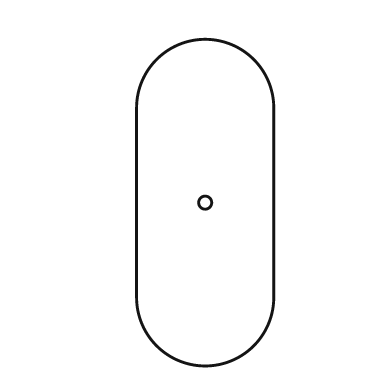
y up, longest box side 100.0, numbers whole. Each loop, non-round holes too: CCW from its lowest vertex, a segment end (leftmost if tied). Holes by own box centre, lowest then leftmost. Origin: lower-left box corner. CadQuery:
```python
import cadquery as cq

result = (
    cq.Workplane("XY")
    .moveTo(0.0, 21.0)
    .threePointArc((21.0, 0.0), (42.0, 21.0))
    .lineTo(42.0, 79.0)
    .threePointArc((21.0, 100.0), (0.0, 79.0))
    .close()
    .moveTo(21.0, 50.0)
    .circle(2.0)
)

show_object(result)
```